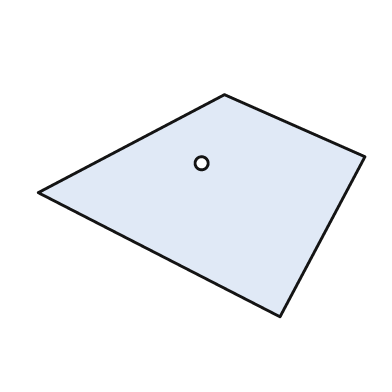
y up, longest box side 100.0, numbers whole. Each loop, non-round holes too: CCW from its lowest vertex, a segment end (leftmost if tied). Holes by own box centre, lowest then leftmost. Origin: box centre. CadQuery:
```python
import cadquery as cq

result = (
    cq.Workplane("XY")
    .moveTo(24.0, -34.0)
    .lineTo(50.0, 15.0)
    .lineTo(7.0, 34.0)
    .lineTo(-50.0, 4.0)
    .close()
    .moveTo(0.0, 13.0)
    .circle(2.0)
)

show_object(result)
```